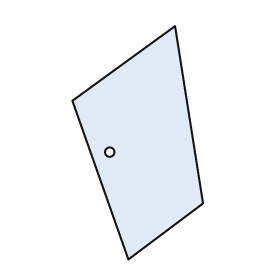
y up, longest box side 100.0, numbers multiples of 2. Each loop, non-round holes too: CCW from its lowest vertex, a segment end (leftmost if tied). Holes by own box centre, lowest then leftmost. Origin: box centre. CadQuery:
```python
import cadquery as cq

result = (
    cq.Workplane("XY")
    .moveTo(-4.0, -50.0)
    .lineTo(28.0, -26.0)
    .lineTo(16.0, 50.0)
    .lineTo(-28.0, 18.0)
    .close()
    .moveTo(-12.0, -4.0)
    .circle(2.0)
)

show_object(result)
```